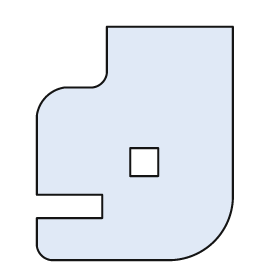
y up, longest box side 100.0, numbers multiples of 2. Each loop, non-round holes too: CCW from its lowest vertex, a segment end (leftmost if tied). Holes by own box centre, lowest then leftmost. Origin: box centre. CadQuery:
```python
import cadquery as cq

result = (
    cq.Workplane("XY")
    .moveTo(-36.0, -50.0)
    .lineTo(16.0, -50.0)
    .threePointArc((34.0, -42.0), (42.0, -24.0))
    .lineTo(42.0, 50.0)
    .lineTo(-12.0, 50.0)
    .lineTo(-12.0, 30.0)
    .threePointArc((-14.0, 26.0), (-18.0, 24.0))
    .lineTo(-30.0, 24.0)
    .threePointArc((-38.0, 20.0), (-42.0, 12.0))
    .lineTo(-42.0, -22.0)
    .lineTo(-14.0, -22.0)
    .lineTo(-14.0, -32.0)
    .lineTo(-42.0, -32.0)
    .lineTo(-42.0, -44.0)
    .threePointArc((-40.0, -48.0), (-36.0, -50.0))
    .close()
    .moveTo(-2.0, -14.0)
    .lineTo(10.0, -14.0)
    .lineTo(10.0, -2.0)
    .lineTo(-2.0, -2.0)
    .close()
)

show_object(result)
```